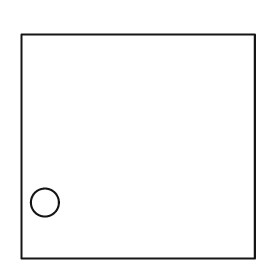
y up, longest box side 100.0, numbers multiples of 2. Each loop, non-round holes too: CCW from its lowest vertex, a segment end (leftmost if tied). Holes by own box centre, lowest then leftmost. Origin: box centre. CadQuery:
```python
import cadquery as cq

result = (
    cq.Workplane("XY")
    .moveTo(-50.0, -48.0)
    .lineTo(50.0, -48.0)
    .lineTo(50.0, 48.0)
    .lineTo(-50.0, 48.0)
    .close()
    .moveTo(-40.0, -24.0)
    .circle(6.0)
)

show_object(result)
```